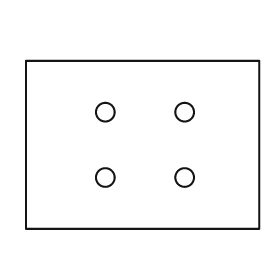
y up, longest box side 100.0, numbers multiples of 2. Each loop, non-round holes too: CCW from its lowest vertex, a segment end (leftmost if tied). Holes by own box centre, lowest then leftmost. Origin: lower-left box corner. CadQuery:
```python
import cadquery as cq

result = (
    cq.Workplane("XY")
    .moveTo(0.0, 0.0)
    .lineTo(100.0, 0.0)
    .lineTo(100.0, 72.0)
    .lineTo(0.0, 72.0)
    .close()
    .moveTo(34.0, 22.0)
    .circle(4.0)
    .moveTo(68.0, 22.0)
    .circle(4.0)
    .moveTo(34.0, 50.0)
    .circle(4.0)
    .moveTo(68.0, 50.0)
    .circle(4.0)
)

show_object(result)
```